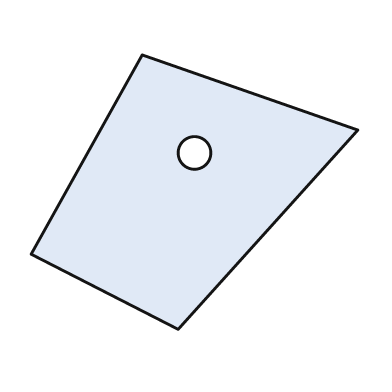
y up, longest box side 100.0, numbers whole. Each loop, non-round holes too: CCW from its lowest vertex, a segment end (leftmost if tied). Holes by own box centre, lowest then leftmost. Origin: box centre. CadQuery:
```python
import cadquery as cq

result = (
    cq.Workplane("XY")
    .moveTo(-5.0, -42.0)
    .lineTo(50.0, 19.0)
    .lineTo(-16.0, 42.0)
    .lineTo(-50.0, -19.0)
    .close()
    .moveTo(0.0, 12.0)
    .circle(5.0)
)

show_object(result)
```